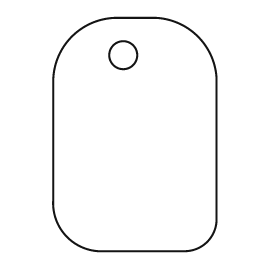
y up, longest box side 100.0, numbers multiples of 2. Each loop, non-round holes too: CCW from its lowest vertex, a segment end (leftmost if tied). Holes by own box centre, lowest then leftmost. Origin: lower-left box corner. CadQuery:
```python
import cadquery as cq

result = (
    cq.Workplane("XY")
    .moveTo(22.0, 0.0)
    .lineTo(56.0, 0.0)
    .threePointArc((66.0, 4.0), (70.0, 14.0))
    .lineTo(70.0, 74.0)
    .threePointArc((62.0, 92.0), (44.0, 100.0))
    .lineTo(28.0, 100.0)
    .threePointArc((8.0, 92.0), (0.0, 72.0))
    .lineTo(0.0, 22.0)
    .threePointArc((6.0, 6.0), (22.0, 0.0))
    .close()
    .moveTo(30.0, 84.0)
    .circle(6.0)
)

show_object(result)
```